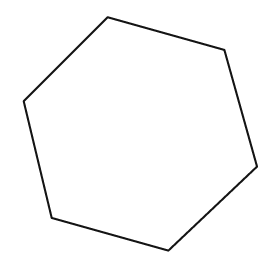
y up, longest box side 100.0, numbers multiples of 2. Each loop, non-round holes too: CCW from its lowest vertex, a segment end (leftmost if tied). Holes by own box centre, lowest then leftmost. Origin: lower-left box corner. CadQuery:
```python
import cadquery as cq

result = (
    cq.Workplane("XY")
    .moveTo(62.0, 0.0)
    .lineTo(100.0, 36.0)
    .lineTo(86.0, 86.0)
    .lineTo(36.0, 100.0)
    .lineTo(0.0, 64.0)
    .lineTo(12.0, 14.0)
    .close()
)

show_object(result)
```